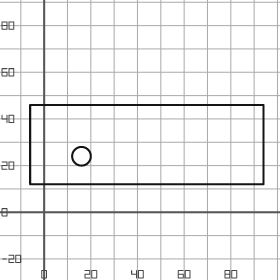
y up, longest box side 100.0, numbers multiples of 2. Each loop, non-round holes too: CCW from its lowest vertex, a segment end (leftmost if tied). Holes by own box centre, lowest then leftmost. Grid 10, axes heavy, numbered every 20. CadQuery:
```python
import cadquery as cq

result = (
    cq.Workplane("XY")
    .moveTo(-6.0, 12.0)
    .lineTo(94.0, 12.0)
    .lineTo(94.0, 46.0)
    .lineTo(-6.0, 46.0)
    .close()
    .moveTo(16.0, 24.0)
    .circle(4.0)
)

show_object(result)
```